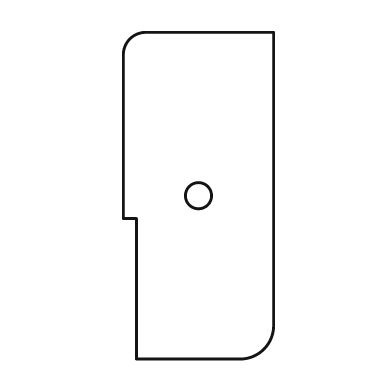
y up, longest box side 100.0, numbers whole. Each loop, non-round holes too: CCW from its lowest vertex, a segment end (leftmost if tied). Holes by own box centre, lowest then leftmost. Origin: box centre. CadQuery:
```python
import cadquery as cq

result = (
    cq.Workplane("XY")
    .moveTo(-19.0, -50.0)
    .lineTo(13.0, -50.0)
    .threePointArc((20.0, -47.0), (23.0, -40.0))
    .lineTo(23.0, 50.0)
    .lineTo(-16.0, 50.0)
    .threePointArc((-21.0, 48.0), (-23.0, 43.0))
    .lineTo(-23.0, -7.0)
    .lineTo(-19.0, -7.0)
    .close()
    .moveTo(0.0, 0.0)
    .circle(4.0)
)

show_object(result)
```